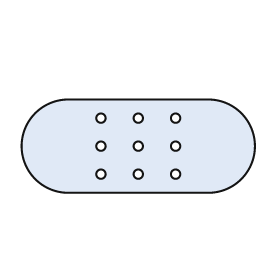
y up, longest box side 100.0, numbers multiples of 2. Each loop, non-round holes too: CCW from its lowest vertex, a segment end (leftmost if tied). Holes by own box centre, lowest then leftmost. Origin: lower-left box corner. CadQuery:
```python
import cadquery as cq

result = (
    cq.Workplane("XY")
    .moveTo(20.0, 0.0)
    .lineTo(80.0, 0.0)
    .threePointArc((100.0, 20.0), (80.0, 40.0))
    .lineTo(20.0, 40.0)
    .threePointArc((0.0, 20.0), (20.0, 0.0))
    .close()
    .moveTo(34.0, 8.0)
    .circle(2.0)
    .moveTo(50.0, 8.0)
    .circle(2.0)
    .moveTo(66.0, 8.0)
    .circle(2.0)
    .moveTo(34.0, 20.0)
    .circle(2.0)
    .moveTo(50.0, 20.0)
    .circle(2.0)
    .moveTo(66.0, 20.0)
    .circle(2.0)
    .moveTo(34.0, 32.0)
    .circle(2.0)
    .moveTo(50.0, 32.0)
    .circle(2.0)
    .moveTo(66.0, 32.0)
    .circle(2.0)
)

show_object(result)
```